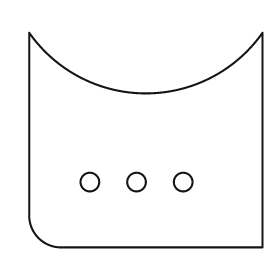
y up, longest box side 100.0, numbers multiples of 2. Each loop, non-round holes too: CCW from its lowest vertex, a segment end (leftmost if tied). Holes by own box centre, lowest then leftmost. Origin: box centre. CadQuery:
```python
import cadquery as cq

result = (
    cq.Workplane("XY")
    .moveTo(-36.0, -46.0)
    .lineTo(50.0, -46.0)
    .lineTo(50.0, 46.0)
    .threePointArc((0.0, 20.0), (-50.0, 46.0))
    .lineTo(-50.0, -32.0)
    .threePointArc((-46.0, -42.0), (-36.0, -46.0))
    .close()
    .moveTo(-24.0, -18.0)
    .circle(4.0)
    .moveTo(-4.0, -18.0)
    .circle(4.0)
    .moveTo(16.0, -18.0)
    .circle(4.0)
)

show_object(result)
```